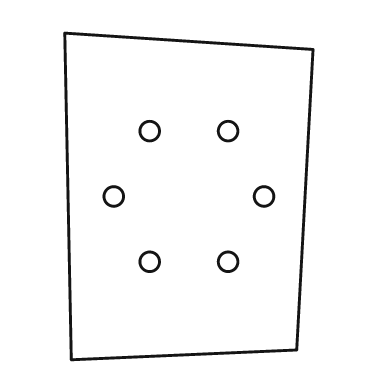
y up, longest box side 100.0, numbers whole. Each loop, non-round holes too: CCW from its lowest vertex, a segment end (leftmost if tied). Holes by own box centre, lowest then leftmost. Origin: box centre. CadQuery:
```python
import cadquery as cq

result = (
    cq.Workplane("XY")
    .moveTo(-36.0, -50.0)
    .lineTo(33.0, -47.0)
    .lineTo(38.0, 45.0)
    .lineTo(-38.0, 50.0)
    .close()
    .moveTo(-12.0, -20.0)
    .circle(3.0)
    .moveTo(12.0, -20.0)
    .circle(3.0)
    .moveTo(-23.0, 0.0)
    .circle(3.0)
    .moveTo(23.0, 0.0)
    .circle(3.0)
    .moveTo(-12.0, 20.0)
    .circle(3.0)
    .moveTo(12.0, 20.0)
    .circle(3.0)
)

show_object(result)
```